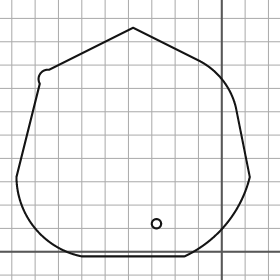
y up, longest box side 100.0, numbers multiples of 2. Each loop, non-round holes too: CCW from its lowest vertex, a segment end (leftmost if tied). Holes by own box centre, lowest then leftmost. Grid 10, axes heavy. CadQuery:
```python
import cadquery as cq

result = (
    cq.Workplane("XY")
    .moveTo(-60.0, -2.0)
    .lineTo(-16.0, -2.0)
    .threePointArc((2.0, 12.0), (12.0, 32.0))
    .lineTo(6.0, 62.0)
    .threePointArc((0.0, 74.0), (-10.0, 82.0))
    .lineTo(-38.0, 96.0)
    .lineTo(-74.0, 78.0)
    .threePointArc((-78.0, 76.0), (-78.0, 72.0))
    .lineTo(-88.0, 32.0)
    .threePointArc((-80.0, 10.0), (-60.0, -2.0))
    .close()
    .moveTo(-28.0, 12.0)
    .circle(2.0)
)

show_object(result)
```